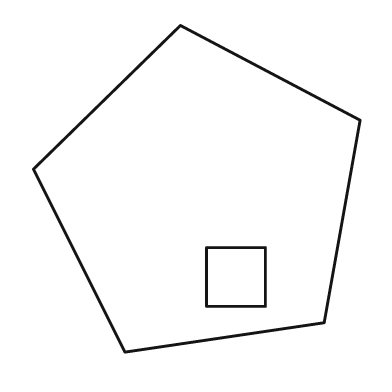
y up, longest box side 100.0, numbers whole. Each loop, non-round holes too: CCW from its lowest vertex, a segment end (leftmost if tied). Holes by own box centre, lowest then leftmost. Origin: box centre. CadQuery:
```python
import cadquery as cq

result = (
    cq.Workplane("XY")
    .moveTo(-22.0, -50.0)
    .lineTo(39.0, -41.0)
    .lineTo(50.0, 21.0)
    .lineTo(-5.0, 50.0)
    .lineTo(-50.0, 6.0)
    .close()
    .moveTo(3.0, -36.0)
    .lineTo(21.0, -36.0)
    .lineTo(21.0, -18.0)
    .lineTo(3.0, -18.0)
    .close()
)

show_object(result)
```